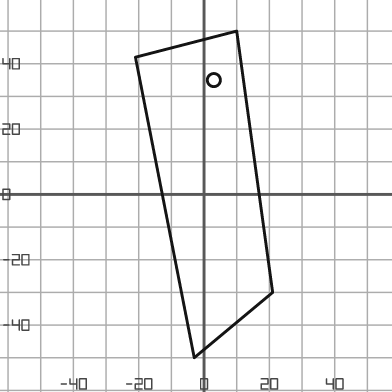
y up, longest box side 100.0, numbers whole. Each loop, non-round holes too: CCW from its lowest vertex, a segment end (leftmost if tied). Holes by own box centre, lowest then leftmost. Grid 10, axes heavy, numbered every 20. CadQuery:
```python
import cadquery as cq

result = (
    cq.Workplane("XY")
    .moveTo(-3.0, -50.0)
    .lineTo(21.0, -30.0)
    .lineTo(10.0, 50.0)
    .lineTo(-21.0, 42.0)
    .close()
    .moveTo(3.0, 35.0)
    .circle(2.0)
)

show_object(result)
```